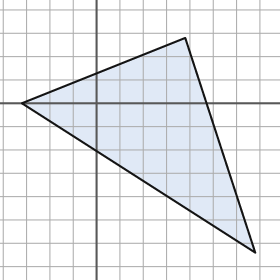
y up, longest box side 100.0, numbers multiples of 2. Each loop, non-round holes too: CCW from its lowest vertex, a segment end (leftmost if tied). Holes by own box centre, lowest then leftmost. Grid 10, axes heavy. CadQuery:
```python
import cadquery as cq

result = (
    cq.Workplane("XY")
    .moveTo(68.0, -64.0)
    .lineTo(38.0, 28.0)
    .lineTo(-32.0, 0.0)
    .close()
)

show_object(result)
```